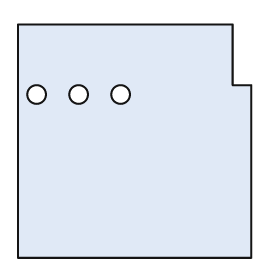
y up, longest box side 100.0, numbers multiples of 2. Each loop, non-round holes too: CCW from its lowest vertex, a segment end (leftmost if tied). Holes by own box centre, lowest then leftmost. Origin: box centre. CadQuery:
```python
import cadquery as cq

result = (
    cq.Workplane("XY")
    .moveTo(-50.0, -50.0)
    .lineTo(50.0, -50.0)
    .lineTo(50.0, 24.0)
    .lineTo(42.0, 24.0)
    .lineTo(42.0, 50.0)
    .lineTo(-50.0, 50.0)
    .close()
    .moveTo(-42.0, 20.0)
    .circle(4.0)
    .moveTo(-24.0, 20.0)
    .circle(4.0)
    .moveTo(-6.0, 20.0)
    .circle(4.0)
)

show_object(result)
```